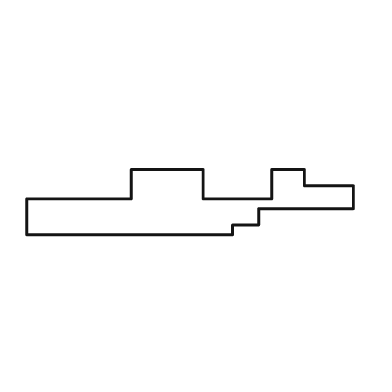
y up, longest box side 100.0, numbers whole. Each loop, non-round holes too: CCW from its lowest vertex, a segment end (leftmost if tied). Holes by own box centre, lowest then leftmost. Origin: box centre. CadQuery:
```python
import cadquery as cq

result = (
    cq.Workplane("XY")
    .moveTo(-50.0, -10.0)
    .lineTo(13.0, -10.0)
    .lineTo(13.0, -7.0)
    .lineTo(21.0, -7.0)
    .lineTo(21.0, -2.0)
    .lineTo(50.0, -2.0)
    .lineTo(50.0, 5.0)
    .lineTo(35.0, 5.0)
    .lineTo(35.0, 10.0)
    .lineTo(25.0, 10.0)
    .lineTo(25.0, 1.0)
    .lineTo(4.0, 1.0)
    .lineTo(4.0, 10.0)
    .lineTo(-18.0, 10.0)
    .lineTo(-18.0, 1.0)
    .lineTo(-50.0, 1.0)
    .close()
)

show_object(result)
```